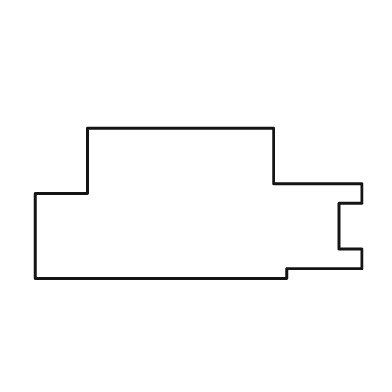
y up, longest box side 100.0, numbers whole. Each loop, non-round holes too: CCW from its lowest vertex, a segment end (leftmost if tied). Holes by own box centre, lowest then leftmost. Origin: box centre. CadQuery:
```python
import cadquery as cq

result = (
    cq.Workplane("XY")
    .moveTo(-50.0, -23.0)
    .lineTo(27.0, -23.0)
    .lineTo(27.0, -20.0)
    .lineTo(50.0, -20.0)
    .lineTo(50.0, -14.0)
    .lineTo(43.0, -14.0)
    .lineTo(43.0, 0.0)
    .lineTo(50.0, 0.0)
    .lineTo(50.0, 6.0)
    .lineTo(23.0, 6.0)
    .lineTo(23.0, 23.0)
    .lineTo(-34.0, 23.0)
    .lineTo(-34.0, 3.0)
    .lineTo(-50.0, 3.0)
    .close()
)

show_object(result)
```